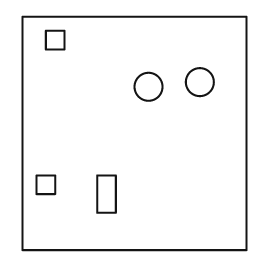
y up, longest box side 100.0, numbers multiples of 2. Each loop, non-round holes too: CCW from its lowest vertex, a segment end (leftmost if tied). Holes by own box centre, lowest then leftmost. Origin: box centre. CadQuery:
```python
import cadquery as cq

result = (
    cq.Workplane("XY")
    .moveTo(-48.0, -50.0)
    .lineTo(48.0, -50.0)
    .lineTo(48.0, 50.0)
    .lineTo(-48.0, 50.0)
    .close()
    .moveTo(-16.0, -34.0)
    .lineTo(-8.0, -34.0)
    .lineTo(-8.0, -18.0)
    .lineTo(-16.0, -18.0)
    .close()
    .moveTo(-42.0, -26.0)
    .lineTo(-34.0, -26.0)
    .lineTo(-34.0, -18.0)
    .lineTo(-42.0, -18.0)
    .close()
    .moveTo(6.0, 20.0)
    .circle(6.0)
    .moveTo(28.0, 22.0)
    .circle(6.0)
    .moveTo(-38.0, 36.0)
    .lineTo(-30.0, 36.0)
    .lineTo(-30.0, 44.0)
    .lineTo(-38.0, 44.0)
    .close()
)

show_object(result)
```